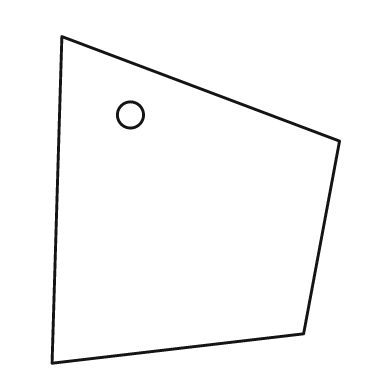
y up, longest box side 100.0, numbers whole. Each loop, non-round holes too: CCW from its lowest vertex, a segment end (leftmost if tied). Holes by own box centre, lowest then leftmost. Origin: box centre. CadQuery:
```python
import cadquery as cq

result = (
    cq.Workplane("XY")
    .moveTo(-44.0, -50.0)
    .lineTo(33.0, -41.0)
    .lineTo(44.0, 18.0)
    .lineTo(-41.0, 50.0)
    .close()
    .moveTo(-20.0, 26.0)
    .circle(4.0)
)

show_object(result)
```